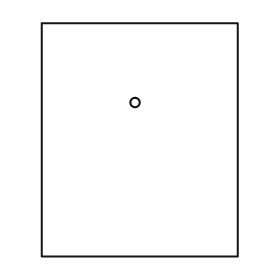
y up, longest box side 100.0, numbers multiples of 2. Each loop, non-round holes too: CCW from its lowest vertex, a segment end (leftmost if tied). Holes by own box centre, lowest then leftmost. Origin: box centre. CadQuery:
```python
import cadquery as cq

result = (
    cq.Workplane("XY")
    .moveTo(-42.0, -50.0)
    .lineTo(42.0, -50.0)
    .lineTo(42.0, 50.0)
    .lineTo(-42.0, 50.0)
    .close()
    .moveTo(-2.0, 16.0)
    .circle(2.0)
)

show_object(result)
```